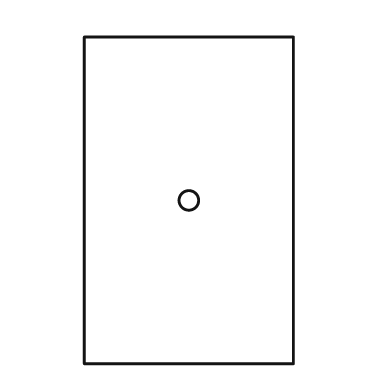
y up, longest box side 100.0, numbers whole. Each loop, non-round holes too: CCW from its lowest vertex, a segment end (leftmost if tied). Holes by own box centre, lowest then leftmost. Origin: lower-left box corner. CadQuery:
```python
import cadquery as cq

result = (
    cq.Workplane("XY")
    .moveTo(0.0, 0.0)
    .lineTo(64.0, 0.0)
    .lineTo(64.0, 100.0)
    .lineTo(0.0, 100.0)
    .close()
    .moveTo(32.0, 50.0)
    .circle(3.0)
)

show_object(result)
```